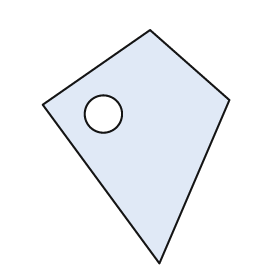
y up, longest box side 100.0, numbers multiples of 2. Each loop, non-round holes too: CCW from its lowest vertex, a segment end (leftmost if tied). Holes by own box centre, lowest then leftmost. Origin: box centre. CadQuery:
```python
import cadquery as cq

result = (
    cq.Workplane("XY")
    .moveTo(10.0, -50.0)
    .lineTo(40.0, 20.0)
    .lineTo(6.0, 50.0)
    .lineTo(-40.0, 18.0)
    .close()
    .moveTo(-14.0, 14.0)
    .circle(8.0)
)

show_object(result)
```